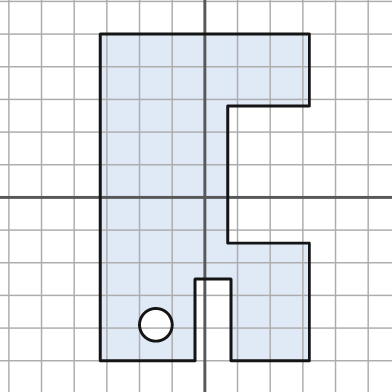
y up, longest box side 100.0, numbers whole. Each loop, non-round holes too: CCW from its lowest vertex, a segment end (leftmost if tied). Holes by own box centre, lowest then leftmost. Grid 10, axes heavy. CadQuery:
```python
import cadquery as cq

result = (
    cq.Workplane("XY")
    .moveTo(-32.0, -50.0)
    .lineTo(-3.0, -50.0)
    .lineTo(-3.0, -25.0)
    .lineTo(8.0, -25.0)
    .lineTo(8.0, -50.0)
    .lineTo(32.0, -50.0)
    .lineTo(32.0, -14.0)
    .lineTo(7.0, -14.0)
    .lineTo(7.0, 28.0)
    .lineTo(32.0, 28.0)
    .lineTo(32.0, 50.0)
    .lineTo(-32.0, 50.0)
    .close()
    .moveTo(-15.0, -39.0)
    .circle(5.0)
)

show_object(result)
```